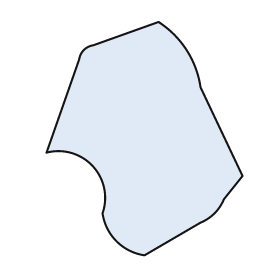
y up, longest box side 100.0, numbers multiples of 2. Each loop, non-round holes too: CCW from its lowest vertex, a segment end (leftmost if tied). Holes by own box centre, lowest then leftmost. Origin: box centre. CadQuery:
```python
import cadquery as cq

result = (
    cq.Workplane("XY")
    .moveTo(0.0, -50.0)
    .lineTo(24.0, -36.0)
    .threePointArc((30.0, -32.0), (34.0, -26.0))
    .lineTo(42.0, -16.0)
    .lineTo(24.0, 22.0)
    .threePointArc((18.0, 38.0), (6.0, 50.0))
    .lineTo(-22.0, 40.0)
    .threePointArc((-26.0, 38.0), (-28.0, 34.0))
    .lineTo(-42.0, -6.0)
    .threePointArc((-22.0, -12.0), (-18.0, -32.0))
    .threePointArc((-12.0, -44.0), (0.0, -50.0))
    .close()
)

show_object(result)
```